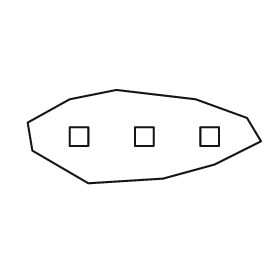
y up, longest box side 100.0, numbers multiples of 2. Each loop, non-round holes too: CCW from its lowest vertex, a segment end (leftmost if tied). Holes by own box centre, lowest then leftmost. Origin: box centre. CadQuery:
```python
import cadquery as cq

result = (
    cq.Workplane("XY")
    .moveTo(-24.0, -20.0)
    .lineTo(8.0, -18.0)
    .lineTo(30.0, -12.0)
    .lineTo(50.0, -2.0)
    .lineTo(44.0, 8.0)
    .lineTo(22.0, 16.0)
    .lineTo(-12.0, 20.0)
    .lineTo(-32.0, 16.0)
    .lineTo(-50.0, 6.0)
    .lineTo(-48.0, -6.0)
    .close()
    .moveTo(-32.0, -4.0)
    .lineTo(-24.0, -4.0)
    .lineTo(-24.0, 4.0)
    .lineTo(-32.0, 4.0)
    .close()
    .moveTo(-4.0, -4.0)
    .lineTo(4.0, -4.0)
    .lineTo(4.0, 4.0)
    .lineTo(-4.0, 4.0)
    .close()
    .moveTo(24.0, -4.0)
    .lineTo(32.0, -4.0)
    .lineTo(32.0, 4.0)
    .lineTo(24.0, 4.0)
    .close()
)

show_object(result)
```